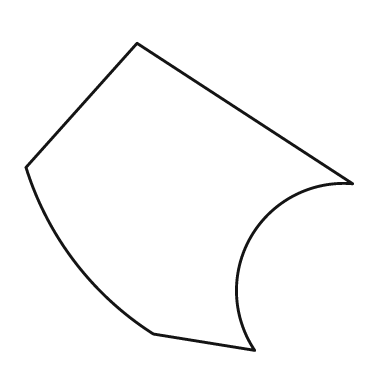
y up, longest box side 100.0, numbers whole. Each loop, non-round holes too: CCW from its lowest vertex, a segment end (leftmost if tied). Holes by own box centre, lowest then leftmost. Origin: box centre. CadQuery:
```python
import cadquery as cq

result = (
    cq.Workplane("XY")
    .moveTo(20.0, -47.0)
    .threePointArc((19.0, -12.0), (50.0, 4.0))
    .lineTo(-16.0, 47.0)
    .lineTo(-50.0, 9.0)
    .threePointArc((-35.0, -20.0), (-11.0, -42.0))
    .close()
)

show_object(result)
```